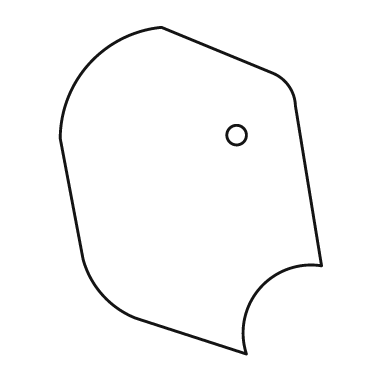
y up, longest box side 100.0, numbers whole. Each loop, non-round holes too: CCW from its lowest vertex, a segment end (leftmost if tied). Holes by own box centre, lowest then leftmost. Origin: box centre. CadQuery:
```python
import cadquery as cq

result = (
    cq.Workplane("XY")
    .moveTo(17.0, -50.0)
    .threePointArc((21.0, -30.0), (40.0, -23.0))
    .lineTo(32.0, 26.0)
    .threePointArc((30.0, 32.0), (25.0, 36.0))
    .lineTo(-9.0, 50.0)
    .threePointArc((-31.0, 39.0), (-40.0, 16.0))
    .lineTo(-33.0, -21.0)
    .threePointArc((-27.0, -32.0), (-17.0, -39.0))
    .close()
    .moveTo(14.0, 17.0)
    .circle(3.0)
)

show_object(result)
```